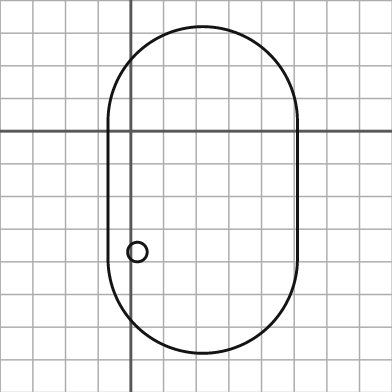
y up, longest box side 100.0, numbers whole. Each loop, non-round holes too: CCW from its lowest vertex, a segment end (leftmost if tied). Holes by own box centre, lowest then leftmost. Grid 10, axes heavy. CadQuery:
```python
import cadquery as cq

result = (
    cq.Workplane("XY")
    .moveTo(-7.0, -39.0)
    .threePointArc((22.0, -68.0), (51.0, -39.0))
    .lineTo(51.0, 3.0)
    .threePointArc((22.0, 32.0), (-7.0, 3.0))
    .close()
    .moveTo(2.0, -37.0)
    .circle(3.0)
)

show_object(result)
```